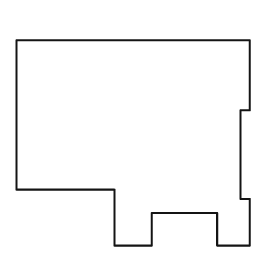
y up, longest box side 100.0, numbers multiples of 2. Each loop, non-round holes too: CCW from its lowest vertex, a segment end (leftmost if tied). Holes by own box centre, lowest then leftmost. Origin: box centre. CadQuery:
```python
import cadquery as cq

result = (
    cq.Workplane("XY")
    .moveTo(-8.0, -44.0)
    .lineTo(8.0, -44.0)
    .lineTo(8.0, -30.0)
    .lineTo(36.0, -30.0)
    .lineTo(36.0, -44.0)
    .lineTo(50.0, -44.0)
    .lineTo(50.0, -24.0)
    .lineTo(46.0, -24.0)
    .lineTo(46.0, 14.0)
    .lineTo(50.0, 14.0)
    .lineTo(50.0, 44.0)
    .lineTo(-50.0, 44.0)
    .lineTo(-50.0, -20.0)
    .lineTo(-8.0, -20.0)
    .close()
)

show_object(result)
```